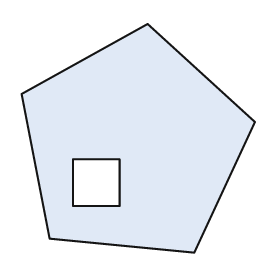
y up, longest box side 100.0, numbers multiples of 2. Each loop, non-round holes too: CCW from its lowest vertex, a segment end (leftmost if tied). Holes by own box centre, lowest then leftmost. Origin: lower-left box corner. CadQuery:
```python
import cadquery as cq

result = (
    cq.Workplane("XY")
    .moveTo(74.0, 0.0)
    .lineTo(100.0, 56.0)
    .lineTo(54.0, 98.0)
    .lineTo(0.0, 68.0)
    .lineTo(12.0, 6.0)
    .close()
    .moveTo(22.0, 20.0)
    .lineTo(42.0, 20.0)
    .lineTo(42.0, 40.0)
    .lineTo(22.0, 40.0)
    .close()
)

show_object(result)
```